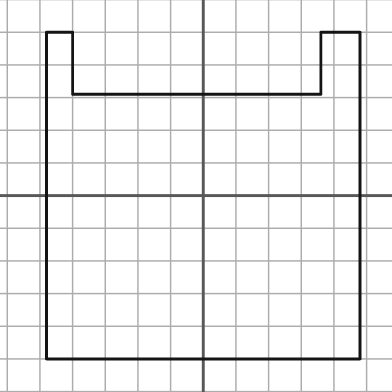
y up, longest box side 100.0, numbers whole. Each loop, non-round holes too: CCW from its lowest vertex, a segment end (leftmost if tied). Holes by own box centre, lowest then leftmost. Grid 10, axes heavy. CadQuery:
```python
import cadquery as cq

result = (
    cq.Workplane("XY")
    .moveTo(-48.0, -50.0)
    .lineTo(48.0, -50.0)
    .lineTo(48.0, 50.0)
    .lineTo(36.0, 50.0)
    .lineTo(36.0, 31.0)
    .lineTo(-40.0, 31.0)
    .lineTo(-40.0, 50.0)
    .lineTo(-48.0, 50.0)
    .close()
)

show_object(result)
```